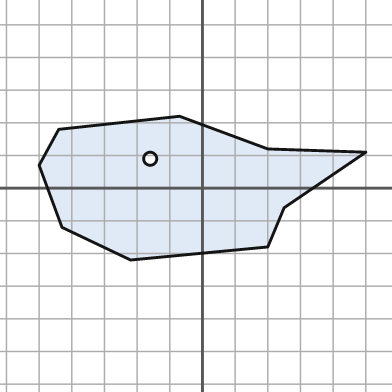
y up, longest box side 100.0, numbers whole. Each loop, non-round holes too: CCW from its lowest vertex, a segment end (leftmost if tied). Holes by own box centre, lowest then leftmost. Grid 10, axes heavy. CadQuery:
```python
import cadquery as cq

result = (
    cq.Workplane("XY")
    .moveTo(-22.0, -22.0)
    .lineTo(20.0, -18.0)
    .lineTo(25.0, -6.0)
    .lineTo(50.0, 11.0)
    .lineTo(20.0, 12.0)
    .lineTo(-7.0, 22.0)
    .lineTo(-44.0, 18.0)
    .lineTo(-50.0, 7.0)
    .lineTo(-43.0, -12.0)
    .close()
    .moveTo(-16.0, 9.0)
    .circle(2.0)
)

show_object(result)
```